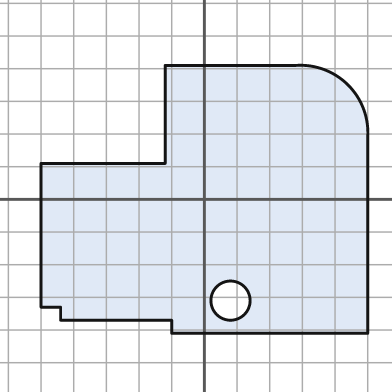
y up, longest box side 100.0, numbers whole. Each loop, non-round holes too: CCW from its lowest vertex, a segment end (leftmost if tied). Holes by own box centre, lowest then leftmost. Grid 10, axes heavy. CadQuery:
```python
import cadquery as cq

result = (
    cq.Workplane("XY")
    .moveTo(-10.0, -41.0)
    .lineTo(50.0, -41.0)
    .lineTo(50.0, 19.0)
    .threePointArc((44.0, 35.0), (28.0, 41.0))
    .lineTo(-12.0, 41.0)
    .lineTo(-12.0, 11.0)
    .lineTo(-50.0, 11.0)
    .lineTo(-50.0, -33.0)
    .lineTo(-44.0, -33.0)
    .lineTo(-44.0, -37.0)
    .lineTo(-10.0, -37.0)
    .close()
    .moveTo(8.0, -31.0)
    .circle(6.0)
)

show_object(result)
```